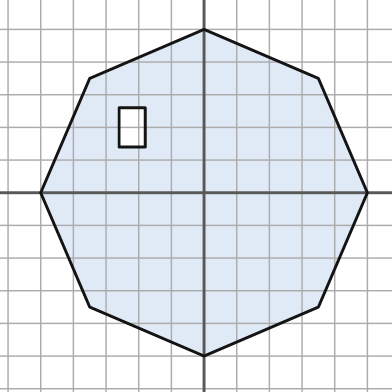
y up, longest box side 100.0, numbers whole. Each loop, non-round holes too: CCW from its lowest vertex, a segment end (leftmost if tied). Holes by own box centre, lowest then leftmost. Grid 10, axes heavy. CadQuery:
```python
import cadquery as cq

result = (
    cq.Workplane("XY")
    .moveTo(0.0, -50.0)
    .lineTo(35.0, -35.0)
    .lineTo(50.0, 0.0)
    .lineTo(35.0, 35.0)
    .lineTo(0.0, 50.0)
    .lineTo(-35.0, 35.0)
    .lineTo(-50.0, 0.0)
    .lineTo(-35.0, -35.0)
    .close()
    .moveTo(-26.0, 14.0)
    .lineTo(-18.0, 14.0)
    .lineTo(-18.0, 26.0)
    .lineTo(-26.0, 26.0)
    .close()
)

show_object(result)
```